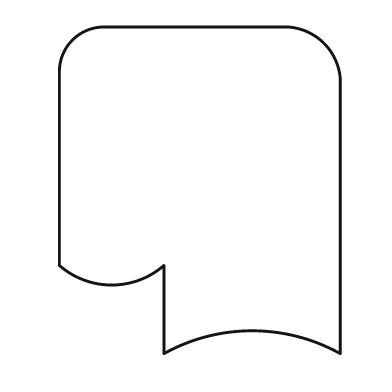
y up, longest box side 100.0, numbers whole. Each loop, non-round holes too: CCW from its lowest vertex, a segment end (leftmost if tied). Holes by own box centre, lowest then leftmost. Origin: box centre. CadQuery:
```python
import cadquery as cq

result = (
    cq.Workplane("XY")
    .moveTo(-11.0, -50.0)
    .threePointArc((16.0, -43.0), (43.0, -50.0))
    .lineTo(43.0, 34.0)
    .threePointArc((38.0, 45.0), (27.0, 50.0))
    .lineTo(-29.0, 50.0)
    .threePointArc((-39.0, 46.0), (-43.0, 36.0))
    .lineTo(-43.0, -23.0)
    .threePointArc((-27.0, -29.0), (-11.0, -23.0))
    .close()
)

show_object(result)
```